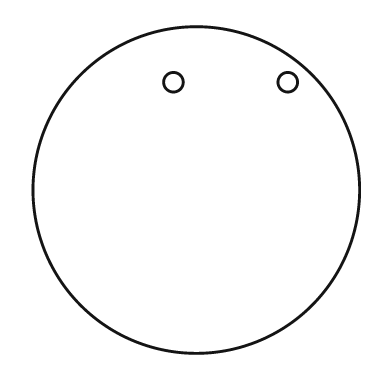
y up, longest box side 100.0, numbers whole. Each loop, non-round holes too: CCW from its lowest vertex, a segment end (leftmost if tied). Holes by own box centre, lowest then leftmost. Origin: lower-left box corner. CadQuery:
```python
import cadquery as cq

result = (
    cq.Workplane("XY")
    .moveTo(50.0, 50.0)
    .circle(50.0)
    .moveTo(43.0, 83.0)
    .circle(3.0)
    .moveTo(78.0, 83.0)
    .circle(3.0)
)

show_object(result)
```